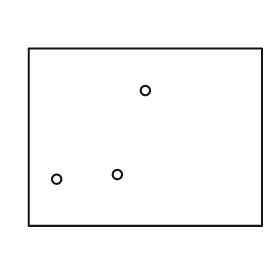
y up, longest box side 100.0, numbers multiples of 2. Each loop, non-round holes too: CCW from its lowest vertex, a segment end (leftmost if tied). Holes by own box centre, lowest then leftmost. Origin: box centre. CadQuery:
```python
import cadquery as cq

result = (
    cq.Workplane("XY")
    .moveTo(-50.0, -38.0)
    .lineTo(50.0, -38.0)
    .lineTo(50.0, 38.0)
    .lineTo(-50.0, 38.0)
    .close()
    .moveTo(-38.0, -18.0)
    .circle(2.0)
    .moveTo(-12.0, -16.0)
    .circle(2.0)
    .moveTo(0.0, 20.0)
    .circle(2.0)
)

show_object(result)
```